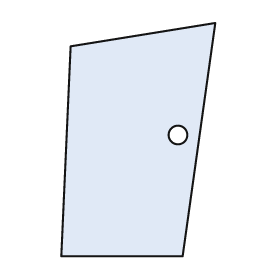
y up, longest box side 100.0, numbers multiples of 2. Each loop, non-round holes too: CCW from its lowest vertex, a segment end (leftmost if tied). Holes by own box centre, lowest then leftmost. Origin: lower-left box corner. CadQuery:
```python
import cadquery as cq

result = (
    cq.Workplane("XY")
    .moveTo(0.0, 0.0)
    .lineTo(52.0, 0.0)
    .lineTo(66.0, 100.0)
    .lineTo(4.0, 90.0)
    .close()
    .moveTo(50.0, 52.0)
    .circle(4.0)
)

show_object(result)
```